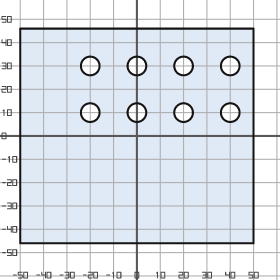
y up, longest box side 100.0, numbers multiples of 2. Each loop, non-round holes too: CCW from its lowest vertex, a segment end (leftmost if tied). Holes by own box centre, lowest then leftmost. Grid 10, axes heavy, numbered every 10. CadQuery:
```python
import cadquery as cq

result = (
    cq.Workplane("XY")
    .moveTo(-50.0, -46.0)
    .lineTo(50.0, -46.0)
    .lineTo(50.0, 46.0)
    .lineTo(-50.0, 46.0)
    .close()
    .moveTo(-20.0, 10.0)
    .circle(4.0)
    .moveTo(0.0, 10.0)
    .circle(4.0)
    .moveTo(20.0, 10.0)
    .circle(4.0)
    .moveTo(40.0, 10.0)
    .circle(4.0)
    .moveTo(-20.0, 30.0)
    .circle(4.0)
    .moveTo(0.0, 30.0)
    .circle(4.0)
    .moveTo(20.0, 30.0)
    .circle(4.0)
    .moveTo(40.0, 30.0)
    .circle(4.0)
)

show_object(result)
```